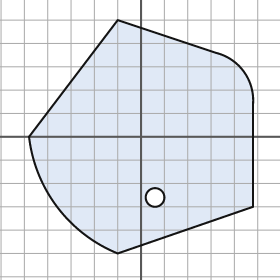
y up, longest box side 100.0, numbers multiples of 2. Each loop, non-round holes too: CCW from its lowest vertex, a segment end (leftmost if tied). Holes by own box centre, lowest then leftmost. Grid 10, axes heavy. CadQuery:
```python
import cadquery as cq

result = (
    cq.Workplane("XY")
    .moveTo(-10.0, -50.0)
    .lineTo(48.0, -30.0)
    .lineTo(48.0, 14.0)
    .threePointArc((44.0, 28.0), (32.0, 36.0))
    .lineTo(-10.0, 50.0)
    .lineTo(-48.0, 0.0)
    .threePointArc((-36.0, -30.0), (-10.0, -50.0))
    .close()
    .moveTo(6.0, -26.0)
    .circle(4.0)
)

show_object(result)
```